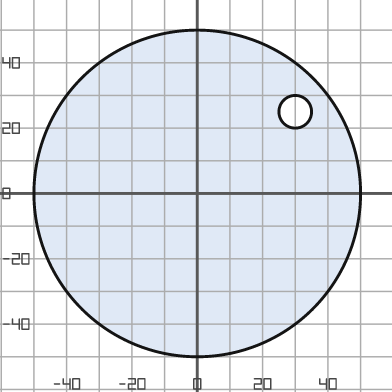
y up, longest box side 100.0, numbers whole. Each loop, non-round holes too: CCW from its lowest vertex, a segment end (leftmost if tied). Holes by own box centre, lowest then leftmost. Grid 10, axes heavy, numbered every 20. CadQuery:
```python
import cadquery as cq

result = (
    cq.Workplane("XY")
    .moveTo(0.0, 0.0)
    .circle(50.0)
    .moveTo(30.0, 25.0)
    .circle(5.0)
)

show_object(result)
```